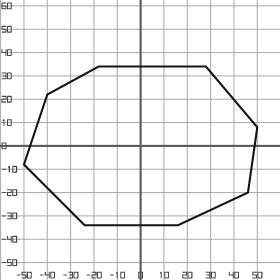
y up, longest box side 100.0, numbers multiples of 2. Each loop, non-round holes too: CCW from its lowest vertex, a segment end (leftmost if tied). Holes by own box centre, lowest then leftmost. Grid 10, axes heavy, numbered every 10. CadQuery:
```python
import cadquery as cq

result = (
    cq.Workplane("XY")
    .moveTo(-24.0, -34.0)
    .lineTo(16.0, -34.0)
    .lineTo(46.0, -20.0)
    .lineTo(50.0, 8.0)
    .lineTo(28.0, 34.0)
    .lineTo(-18.0, 34.0)
    .lineTo(-40.0, 22.0)
    .lineTo(-50.0, -8.0)
    .close()
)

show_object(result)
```